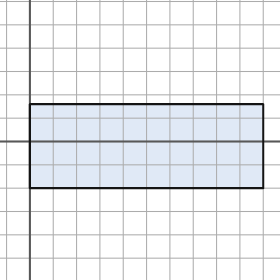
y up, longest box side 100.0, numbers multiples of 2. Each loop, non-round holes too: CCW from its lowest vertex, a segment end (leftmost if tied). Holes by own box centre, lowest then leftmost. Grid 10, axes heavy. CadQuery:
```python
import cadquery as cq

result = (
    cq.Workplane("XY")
    .moveTo(0.0, -20.0)
    .lineTo(100.0, -20.0)
    .lineTo(100.0, 16.0)
    .lineTo(0.0, 16.0)
    .close()
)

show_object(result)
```